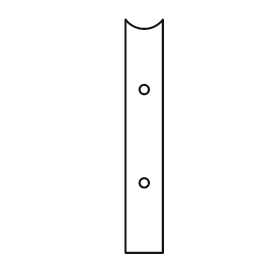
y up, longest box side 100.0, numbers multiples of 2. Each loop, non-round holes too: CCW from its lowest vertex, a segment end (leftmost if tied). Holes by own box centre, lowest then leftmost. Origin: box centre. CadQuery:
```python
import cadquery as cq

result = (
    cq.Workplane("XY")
    .moveTo(-8.0, -50.0)
    .lineTo(8.0, -50.0)
    .lineTo(8.0, 50.0)
    .threePointArc((0.0, 46.0), (-8.0, 50.0))
    .close()
    .moveTo(0.0, -20.0)
    .circle(2.0)
    .moveTo(0.0, 20.0)
    .circle(2.0)
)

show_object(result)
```